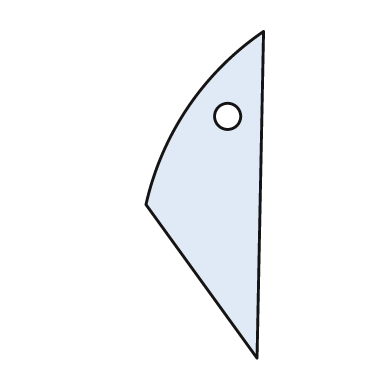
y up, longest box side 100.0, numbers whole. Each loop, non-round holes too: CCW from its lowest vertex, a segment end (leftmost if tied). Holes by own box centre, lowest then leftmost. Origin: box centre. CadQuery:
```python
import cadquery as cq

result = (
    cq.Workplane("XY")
    .moveTo(16.0, -50.0)
    .lineTo(18.0, 50.0)
    .threePointArc((-5.0, 27.0), (-18.0, -3.0))
    .close()
    .moveTo(7.0, 24.0)
    .circle(4.0)
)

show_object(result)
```